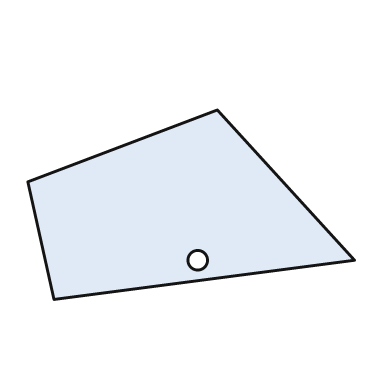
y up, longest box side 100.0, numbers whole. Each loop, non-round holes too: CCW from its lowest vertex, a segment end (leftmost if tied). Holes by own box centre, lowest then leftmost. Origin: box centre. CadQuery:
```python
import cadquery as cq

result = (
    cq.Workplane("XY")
    .moveTo(-42.0, -29.0)
    .lineTo(50.0, -17.0)
    .lineTo(8.0, 29.0)
    .lineTo(-50.0, 7.0)
    .close()
    .moveTo(2.0, -17.0)
    .circle(3.0)
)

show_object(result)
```